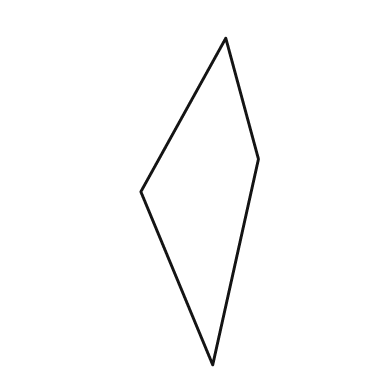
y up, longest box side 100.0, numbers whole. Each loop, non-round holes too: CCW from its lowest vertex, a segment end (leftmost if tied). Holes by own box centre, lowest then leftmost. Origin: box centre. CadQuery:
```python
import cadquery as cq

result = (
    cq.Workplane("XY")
    .moveTo(4.0, -50.0)
    .lineTo(18.0, 13.0)
    .lineTo(8.0, 50.0)
    .lineTo(-18.0, 3.0)
    .close()
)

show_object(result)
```